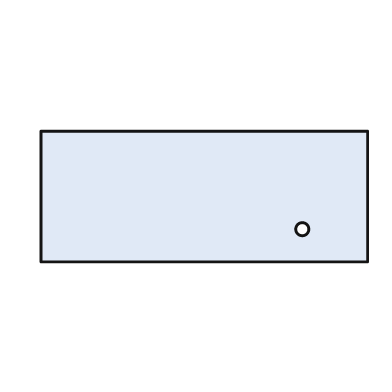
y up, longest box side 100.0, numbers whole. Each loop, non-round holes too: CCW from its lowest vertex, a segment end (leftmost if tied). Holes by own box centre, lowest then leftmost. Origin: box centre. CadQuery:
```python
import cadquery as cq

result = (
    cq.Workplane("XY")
    .moveTo(-50.0, -20.0)
    .lineTo(50.0, -20.0)
    .lineTo(50.0, 20.0)
    .lineTo(-50.0, 20.0)
    .close()
    .moveTo(30.0, -10.0)
    .circle(2.0)
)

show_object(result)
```